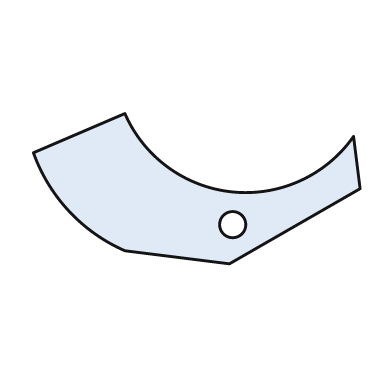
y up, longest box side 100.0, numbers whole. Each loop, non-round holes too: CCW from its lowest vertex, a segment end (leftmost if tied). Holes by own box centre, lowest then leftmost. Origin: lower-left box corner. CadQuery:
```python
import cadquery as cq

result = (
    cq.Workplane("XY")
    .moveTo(60.0, 0.0)
    .lineTo(100.0, 23.0)
    .lineTo(98.0, 39.0)
    .threePointArc((61.0, 22.0), (28.0, 46.0))
    .lineTo(0.0, 34.0)
    .threePointArc((11.0, 16.0), (28.0, 4.0))
    .close()
    .moveTo(61.0, 12.0)
    .circle(4.0)
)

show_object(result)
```